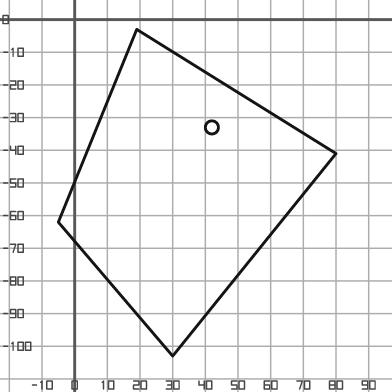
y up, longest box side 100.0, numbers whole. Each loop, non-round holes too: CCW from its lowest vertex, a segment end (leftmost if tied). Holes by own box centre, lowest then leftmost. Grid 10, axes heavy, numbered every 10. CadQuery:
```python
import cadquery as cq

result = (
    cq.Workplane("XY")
    .moveTo(30.0, -103.0)
    .lineTo(80.0, -41.0)
    .lineTo(19.0, -3.0)
    .lineTo(-5.0, -62.0)
    .close()
    .moveTo(42.0, -33.0)
    .circle(2.0)
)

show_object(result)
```